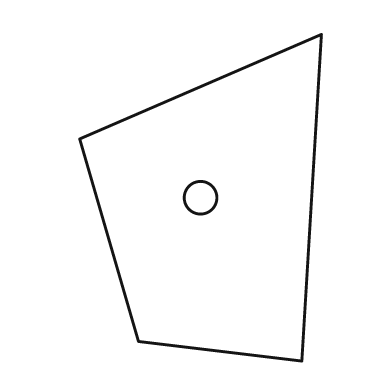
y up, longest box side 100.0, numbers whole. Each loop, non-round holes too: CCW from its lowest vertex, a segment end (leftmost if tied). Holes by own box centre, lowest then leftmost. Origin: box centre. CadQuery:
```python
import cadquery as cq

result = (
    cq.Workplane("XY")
    .moveTo(31.0, -50.0)
    .lineTo(37.0, 50.0)
    .lineTo(-37.0, 18.0)
    .lineTo(-19.0, -44.0)
    .close()
    .moveTo(0.0, 0.0)
    .circle(5.0)
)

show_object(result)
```